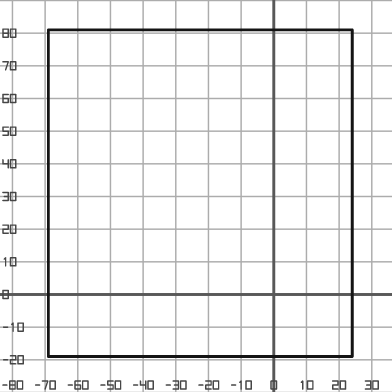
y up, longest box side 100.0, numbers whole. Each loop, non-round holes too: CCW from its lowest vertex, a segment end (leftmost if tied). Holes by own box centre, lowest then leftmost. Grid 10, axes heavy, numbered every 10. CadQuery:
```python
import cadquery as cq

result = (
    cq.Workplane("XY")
    .moveTo(-69.0, -19.0)
    .lineTo(24.0, -19.0)
    .lineTo(24.0, 81.0)
    .lineTo(-69.0, 81.0)
    .close()
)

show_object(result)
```